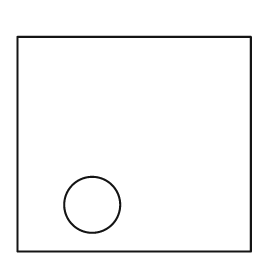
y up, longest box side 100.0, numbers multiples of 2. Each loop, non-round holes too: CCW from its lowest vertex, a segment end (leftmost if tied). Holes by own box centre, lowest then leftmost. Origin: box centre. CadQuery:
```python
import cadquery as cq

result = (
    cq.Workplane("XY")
    .moveTo(-50.0, -46.0)
    .lineTo(50.0, -46.0)
    .lineTo(50.0, 46.0)
    .lineTo(-50.0, 46.0)
    .close()
    .moveTo(-18.0, -26.0)
    .circle(12.0)
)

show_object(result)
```